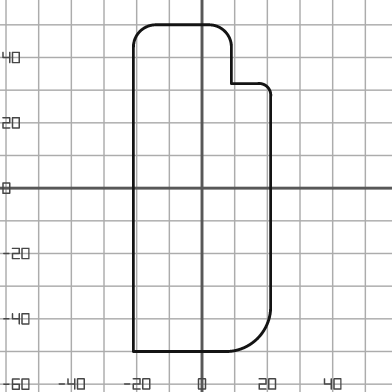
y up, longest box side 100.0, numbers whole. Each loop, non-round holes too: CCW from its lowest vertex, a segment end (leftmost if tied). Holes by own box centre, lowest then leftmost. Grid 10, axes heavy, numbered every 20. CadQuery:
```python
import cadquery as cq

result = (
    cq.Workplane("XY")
    .moveTo(-21.0, -50.0)
    .lineTo(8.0, -50.0)
    .threePointArc((17.0, -46.0), (21.0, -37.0))
    .lineTo(21.0, 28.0)
    .threePointArc((20.0, 31.0), (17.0, 32.0))
    .lineTo(9.0, 32.0)
    .lineTo(9.0, 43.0)
    .threePointArc((7.0, 48.0), (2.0, 50.0))
    .lineTo(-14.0, 50.0)
    .threePointArc((-19.0, 48.0), (-21.0, 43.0))
    .close()
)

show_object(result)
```